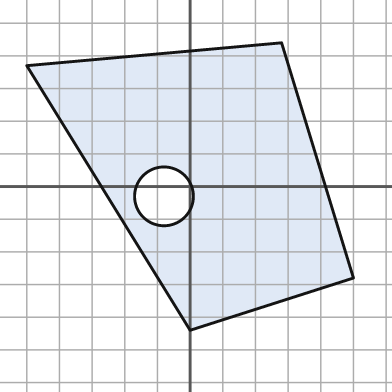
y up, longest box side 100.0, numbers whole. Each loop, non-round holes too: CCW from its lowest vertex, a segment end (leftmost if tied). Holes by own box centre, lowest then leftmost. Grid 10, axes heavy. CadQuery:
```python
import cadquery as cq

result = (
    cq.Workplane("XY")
    .moveTo(0.0, -44.0)
    .lineTo(50.0, -28.0)
    .lineTo(28.0, 44.0)
    .lineTo(-50.0, 37.0)
    .close()
    .moveTo(-8.0, -3.0)
    .circle(9.0)
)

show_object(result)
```